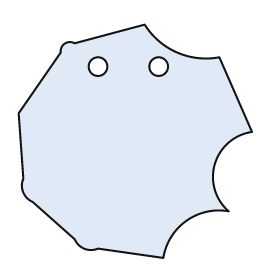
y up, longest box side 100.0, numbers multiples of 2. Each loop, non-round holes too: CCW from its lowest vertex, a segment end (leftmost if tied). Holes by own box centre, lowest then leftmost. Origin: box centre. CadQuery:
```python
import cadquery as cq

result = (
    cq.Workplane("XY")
    .moveTo(12.0, -50.0)
    .threePointArc((22.0, -34.0), (40.0, -30.0))
    .threePointArc((34.0, -10.0), (50.0, 4.0))
    .lineTo(36.0, 36.0)
    .threePointArc((18.0, 38.0), (4.0, 50.0))
    .lineTo(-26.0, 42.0)
    .threePointArc((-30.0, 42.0), (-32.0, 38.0))
    .lineTo(-50.0, 12.0)
    .lineTo(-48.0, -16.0)
    .threePointArc((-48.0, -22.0), (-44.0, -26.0))
    .lineTo(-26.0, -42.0)
    .threePointArc((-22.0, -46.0), (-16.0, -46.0))
    .close()
    .moveTo(-16.0, 32.0)
    .circle(4.0)
    .moveTo(10.0, 32.0)
    .circle(4.0)
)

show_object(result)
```